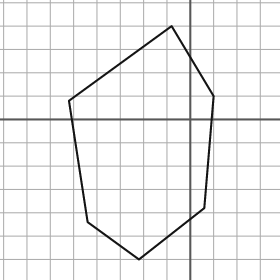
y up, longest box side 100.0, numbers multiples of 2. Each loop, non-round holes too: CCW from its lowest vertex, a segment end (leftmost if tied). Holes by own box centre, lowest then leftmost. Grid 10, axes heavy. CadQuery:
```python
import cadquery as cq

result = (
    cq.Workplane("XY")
    .moveTo(-22.0, -60.0)
    .lineTo(6.0, -38.0)
    .lineTo(10.0, 10.0)
    .lineTo(-8.0, 40.0)
    .lineTo(-52.0, 8.0)
    .lineTo(-44.0, -44.0)
    .close()
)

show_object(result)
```